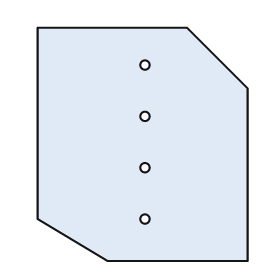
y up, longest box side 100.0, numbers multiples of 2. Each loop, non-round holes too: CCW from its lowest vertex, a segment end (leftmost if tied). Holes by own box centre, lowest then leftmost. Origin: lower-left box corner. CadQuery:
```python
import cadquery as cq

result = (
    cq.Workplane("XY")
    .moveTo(30.0, 0.0)
    .lineTo(90.0, 0.0)
    .lineTo(90.0, 74.0)
    .lineTo(64.0, 100.0)
    .lineTo(0.0, 100.0)
    .lineTo(0.0, 18.0)
    .close()
    .moveTo(46.0, 18.0)
    .circle(2.0)
    .moveTo(46.0, 40.0)
    .circle(2.0)
    .moveTo(46.0, 62.0)
    .circle(2.0)
    .moveTo(46.0, 84.0)
    .circle(2.0)
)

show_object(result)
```